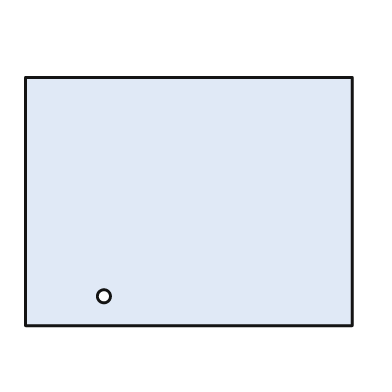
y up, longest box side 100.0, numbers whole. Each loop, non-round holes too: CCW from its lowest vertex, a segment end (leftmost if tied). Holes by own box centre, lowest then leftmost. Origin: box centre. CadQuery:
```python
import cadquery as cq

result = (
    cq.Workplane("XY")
    .moveTo(-50.0, -38.0)
    .lineTo(50.0, -38.0)
    .lineTo(50.0, 38.0)
    .lineTo(-50.0, 38.0)
    .close()
    .moveTo(-26.0, -29.0)
    .circle(2.0)
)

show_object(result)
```